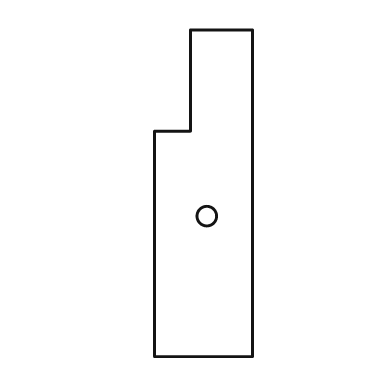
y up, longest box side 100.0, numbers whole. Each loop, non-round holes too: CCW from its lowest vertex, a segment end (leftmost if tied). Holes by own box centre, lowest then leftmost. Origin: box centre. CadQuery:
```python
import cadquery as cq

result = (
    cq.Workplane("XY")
    .moveTo(-15.0, -50.0)
    .lineTo(15.0, -50.0)
    .lineTo(15.0, 50.0)
    .lineTo(-4.0, 50.0)
    .lineTo(-4.0, 19.0)
    .lineTo(-15.0, 19.0)
    .close()
    .moveTo(1.0, -7.0)
    .circle(3.0)
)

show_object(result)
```